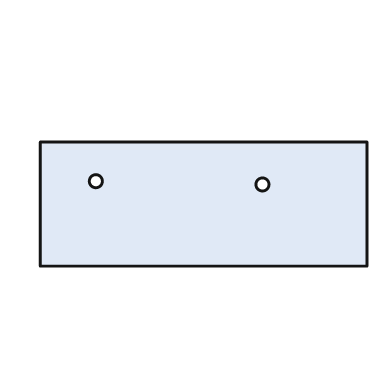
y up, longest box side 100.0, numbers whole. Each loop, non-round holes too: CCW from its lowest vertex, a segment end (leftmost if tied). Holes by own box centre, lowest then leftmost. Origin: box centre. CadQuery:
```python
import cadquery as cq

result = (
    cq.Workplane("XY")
    .moveTo(-50.0, -19.0)
    .lineTo(50.0, -19.0)
    .lineTo(50.0, 19.0)
    .lineTo(-50.0, 19.0)
    .close()
    .moveTo(18.0, 6.0)
    .circle(2.0)
    .moveTo(-33.0, 7.0)
    .circle(2.0)
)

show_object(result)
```